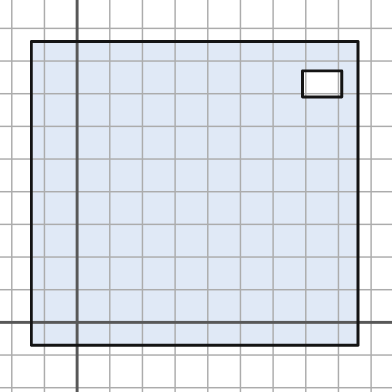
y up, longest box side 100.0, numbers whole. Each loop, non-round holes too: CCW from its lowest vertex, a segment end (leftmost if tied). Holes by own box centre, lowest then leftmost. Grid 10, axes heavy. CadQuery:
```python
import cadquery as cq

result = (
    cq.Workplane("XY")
    .moveTo(-14.0, -7.0)
    .lineTo(86.0, -7.0)
    .lineTo(86.0, 86.0)
    .lineTo(-14.0, 86.0)
    .close()
    .moveTo(69.0, 69.0)
    .lineTo(81.0, 69.0)
    .lineTo(81.0, 77.0)
    .lineTo(69.0, 77.0)
    .close()
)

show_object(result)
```